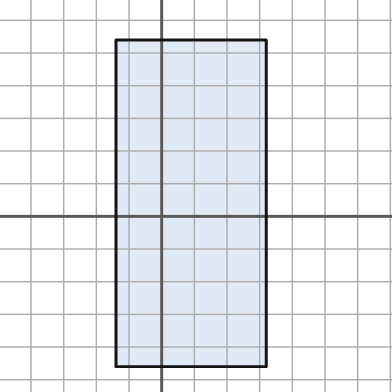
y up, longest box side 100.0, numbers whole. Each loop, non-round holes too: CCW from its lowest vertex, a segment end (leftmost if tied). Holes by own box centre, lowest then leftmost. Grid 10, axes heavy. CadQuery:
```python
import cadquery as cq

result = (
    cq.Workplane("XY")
    .moveTo(-14.0, -46.0)
    .lineTo(32.0, -46.0)
    .lineTo(32.0, 54.0)
    .lineTo(-14.0, 54.0)
    .close()
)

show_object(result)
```